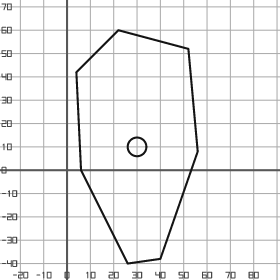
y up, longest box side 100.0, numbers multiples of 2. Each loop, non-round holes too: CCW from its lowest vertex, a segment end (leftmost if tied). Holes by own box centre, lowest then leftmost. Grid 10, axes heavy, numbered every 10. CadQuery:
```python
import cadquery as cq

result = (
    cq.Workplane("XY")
    .moveTo(26.0, -40.0)
    .lineTo(40.0, -38.0)
    .lineTo(56.0, 8.0)
    .lineTo(52.0, 52.0)
    .lineTo(22.0, 60.0)
    .lineTo(4.0, 42.0)
    .lineTo(6.0, 0.0)
    .close()
    .moveTo(30.0, 10.0)
    .circle(4.0)
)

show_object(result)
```